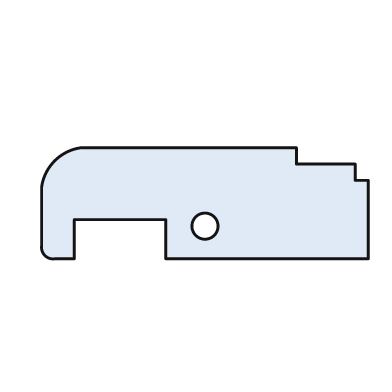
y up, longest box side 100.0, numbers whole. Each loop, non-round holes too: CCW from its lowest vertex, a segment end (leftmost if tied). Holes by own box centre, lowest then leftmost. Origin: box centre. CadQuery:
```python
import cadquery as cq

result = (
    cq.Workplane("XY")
    .moveTo(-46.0, -17.0)
    .lineTo(-40.0, -17.0)
    .lineTo(-40.0, -5.0)
    .lineTo(-12.0, -5.0)
    .lineTo(-12.0, -17.0)
    .lineTo(50.0, -17.0)
    .lineTo(50.0, 7.0)
    .lineTo(46.0, 7.0)
    .lineTo(46.0, 12.0)
    .lineTo(28.0, 12.0)
    .lineTo(28.0, 17.0)
    .lineTo(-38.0, 17.0)
    .threePointArc((-46.0, 13.0), (-50.0, 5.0))
    .lineTo(-50.0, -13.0)
    .threePointArc((-49.0, -16.0), (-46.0, -17.0))
    .close()
    .moveTo(0.0, -7.0)
    .circle(4.0)
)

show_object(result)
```